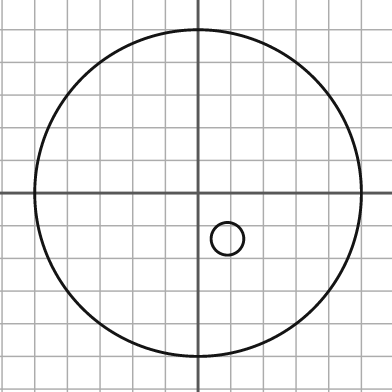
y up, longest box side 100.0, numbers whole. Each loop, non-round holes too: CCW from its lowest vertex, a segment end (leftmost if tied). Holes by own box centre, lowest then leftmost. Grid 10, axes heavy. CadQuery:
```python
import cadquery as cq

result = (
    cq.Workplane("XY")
    .moveTo(0.0, 0.0)
    .circle(50.0)
    .moveTo(9.0, -14.0)
    .circle(5.0)
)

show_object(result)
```